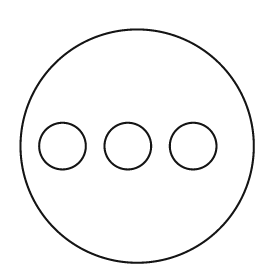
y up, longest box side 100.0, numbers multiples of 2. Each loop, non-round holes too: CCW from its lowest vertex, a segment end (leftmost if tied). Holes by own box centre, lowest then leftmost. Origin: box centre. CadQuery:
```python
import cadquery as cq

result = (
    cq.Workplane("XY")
    .moveTo(0.0, 0.0)
    .circle(50.0)
    .moveTo(-32.0, 0.0)
    .circle(10.0)
    .moveTo(-4.0, 0.0)
    .circle(10.0)
    .moveTo(24.0, 0.0)
    .circle(10.0)
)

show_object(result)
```